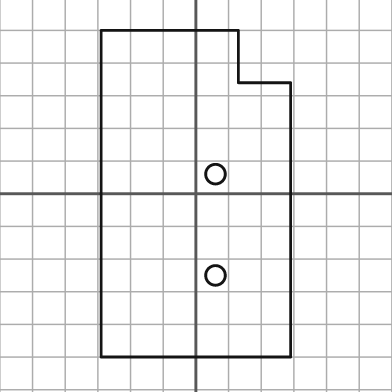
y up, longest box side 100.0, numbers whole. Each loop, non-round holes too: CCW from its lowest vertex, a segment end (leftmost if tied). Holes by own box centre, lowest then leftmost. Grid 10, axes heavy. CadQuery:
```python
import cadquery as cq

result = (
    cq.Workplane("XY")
    .moveTo(-29.0, -50.0)
    .lineTo(29.0, -50.0)
    .lineTo(29.0, 34.0)
    .lineTo(13.0, 34.0)
    .lineTo(13.0, 50.0)
    .lineTo(-29.0, 50.0)
    .close()
    .moveTo(6.0, -25.0)
    .circle(3.0)
    .moveTo(6.0, 6.0)
    .circle(3.0)
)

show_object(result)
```